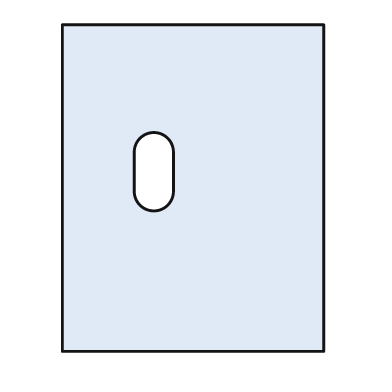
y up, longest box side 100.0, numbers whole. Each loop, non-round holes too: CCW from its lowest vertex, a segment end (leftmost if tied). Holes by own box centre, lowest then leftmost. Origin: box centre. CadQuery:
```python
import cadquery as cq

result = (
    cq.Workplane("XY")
    .moveTo(-40.0, -50.0)
    .lineTo(40.0, -50.0)
    .lineTo(40.0, 50.0)
    .lineTo(-40.0, 50.0)
    .close()
    .moveTo(-18.0, -1.0)
    .threePointArc((-12.0, -7.0), (-6.0, -1.0))
    .lineTo(-6.0, 11.0)
    .threePointArc((-12.0, 17.0), (-18.0, 11.0))
    .close()
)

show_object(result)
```